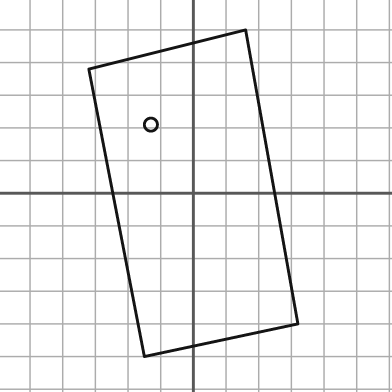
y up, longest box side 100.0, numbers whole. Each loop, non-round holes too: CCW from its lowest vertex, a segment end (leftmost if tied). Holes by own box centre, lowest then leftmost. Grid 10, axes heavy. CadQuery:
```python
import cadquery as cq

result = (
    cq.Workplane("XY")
    .moveTo(-15.0, -50.0)
    .lineTo(32.0, -40.0)
    .lineTo(16.0, 50.0)
    .lineTo(-32.0, 38.0)
    .close()
    .moveTo(-13.0, 21.0)
    .circle(2.0)
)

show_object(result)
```